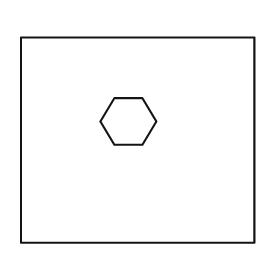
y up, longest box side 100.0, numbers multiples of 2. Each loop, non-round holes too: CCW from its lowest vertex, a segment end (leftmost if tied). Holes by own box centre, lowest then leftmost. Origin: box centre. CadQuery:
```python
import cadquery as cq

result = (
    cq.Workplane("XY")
    .moveTo(-50.0, -44.0)
    .lineTo(50.0, -44.0)
    .lineTo(50.0, 44.0)
    .lineTo(-50.0, 44.0)
    .close()
    .moveTo(-10.0, -2.0)
    .lineTo(2.0, -2.0)
    .lineTo(8.0, 8.0)
    .lineTo(2.0, 18.0)
    .lineTo(-10.0, 18.0)
    .lineTo(-16.0, 8.0)
    .close()
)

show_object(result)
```